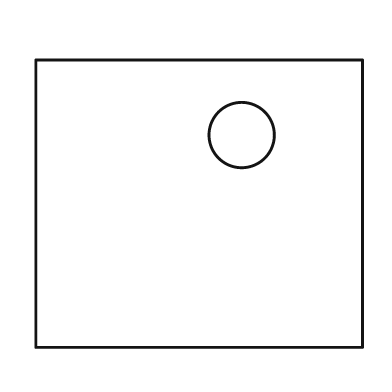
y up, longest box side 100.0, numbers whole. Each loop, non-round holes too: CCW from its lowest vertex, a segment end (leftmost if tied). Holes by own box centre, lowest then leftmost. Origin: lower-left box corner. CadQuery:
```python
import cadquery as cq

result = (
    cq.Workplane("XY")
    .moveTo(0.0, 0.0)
    .lineTo(100.0, 0.0)
    .lineTo(100.0, 88.0)
    .lineTo(0.0, 88.0)
    .close()
    .moveTo(63.0, 65.0)
    .circle(10.0)
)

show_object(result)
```